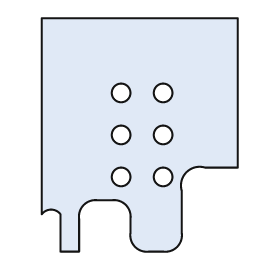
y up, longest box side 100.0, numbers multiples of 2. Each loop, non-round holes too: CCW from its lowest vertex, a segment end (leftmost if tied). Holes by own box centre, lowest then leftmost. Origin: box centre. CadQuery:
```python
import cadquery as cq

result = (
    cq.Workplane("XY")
    .moveTo(-34.0, -50.0)
    .lineTo(-26.0, -50.0)
    .lineTo(-26.0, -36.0)
    .threePointArc((-24.0, -30.0), (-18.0, -28.0))
    .lineTo(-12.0, -28.0)
    .threePointArc((-6.0, -30.0), (-4.0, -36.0))
    .lineTo(-4.0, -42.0)
    .threePointArc((-2.0, -48.0), (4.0, -50.0))
    .lineTo(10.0, -50.0)
    .threePointArc((16.0, -48.0), (18.0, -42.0))
    .lineTo(18.0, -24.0)
    .threePointArc((20.0, -16.0), (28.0, -14.0))
    .lineTo(42.0, -14.0)
    .lineTo(42.0, 50.0)
    .lineTo(-42.0, 50.0)
    .lineTo(-42.0, -34.0)
    .threePointArc((-38.0, -32.0), (-34.0, -34.0))
    .close()
    .moveTo(-8.0, -18.0)
    .circle(4.0)
    .moveTo(10.0, -18.0)
    .circle(4.0)
    .moveTo(-8.0, 0.0)
    .circle(4.0)
    .moveTo(10.0, 0.0)
    .circle(4.0)
    .moveTo(-8.0, 18.0)
    .circle(4.0)
    .moveTo(10.0, 18.0)
    .circle(4.0)
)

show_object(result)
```